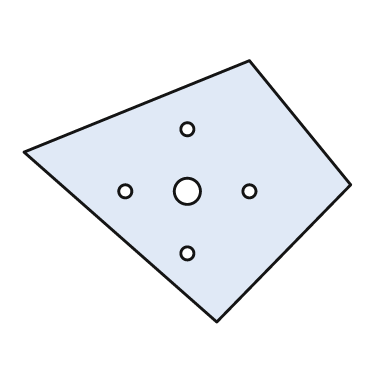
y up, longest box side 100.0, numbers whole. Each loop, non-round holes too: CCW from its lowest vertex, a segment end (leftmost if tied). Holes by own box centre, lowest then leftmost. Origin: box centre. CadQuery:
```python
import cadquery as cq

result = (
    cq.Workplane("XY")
    .moveTo(9.0, -40.0)
    .lineTo(50.0, 2.0)
    .lineTo(19.0, 40.0)
    .lineTo(-50.0, 12.0)
    .close()
    .moveTo(0.0, -19.0)
    .circle(2.0)
    .moveTo(-19.0, 0.0)
    .circle(2.0)
    .moveTo(0.0, 0.0)
    .circle(4.0)
    .moveTo(19.0, 0.0)
    .circle(2.0)
    .moveTo(0.0, 19.0)
    .circle(2.0)
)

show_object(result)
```